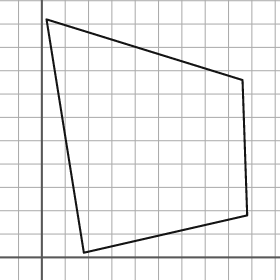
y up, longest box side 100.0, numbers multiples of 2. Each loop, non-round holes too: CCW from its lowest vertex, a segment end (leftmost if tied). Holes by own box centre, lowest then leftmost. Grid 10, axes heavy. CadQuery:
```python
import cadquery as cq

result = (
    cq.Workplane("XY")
    .moveTo(18.0, 2.0)
    .lineTo(88.0, 18.0)
    .lineTo(86.0, 76.0)
    .lineTo(2.0, 102.0)
    .close()
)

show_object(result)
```